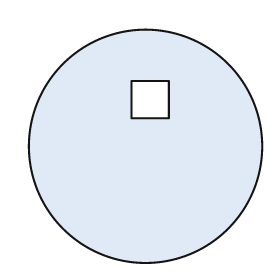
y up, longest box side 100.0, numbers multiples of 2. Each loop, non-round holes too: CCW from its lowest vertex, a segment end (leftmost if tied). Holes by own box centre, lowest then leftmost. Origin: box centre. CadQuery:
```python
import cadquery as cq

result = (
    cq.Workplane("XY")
    .moveTo(0.0, 0.0)
    .circle(50.0)
    .moveTo(-6.0, 12.0)
    .lineTo(10.0, 12.0)
    .lineTo(10.0, 28.0)
    .lineTo(-6.0, 28.0)
    .close()
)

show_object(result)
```